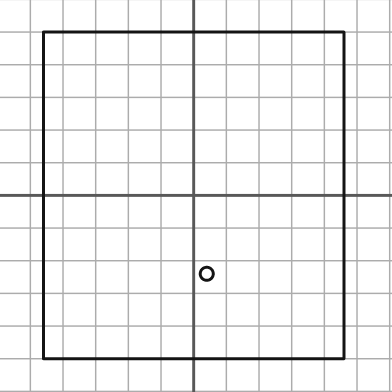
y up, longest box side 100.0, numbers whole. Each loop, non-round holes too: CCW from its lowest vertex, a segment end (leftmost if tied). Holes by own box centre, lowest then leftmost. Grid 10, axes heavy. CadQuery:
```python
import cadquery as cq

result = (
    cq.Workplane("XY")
    .moveTo(-46.0, -50.0)
    .lineTo(46.0, -50.0)
    .lineTo(46.0, 50.0)
    .lineTo(-46.0, 50.0)
    .close()
    .moveTo(4.0, -24.0)
    .circle(2.0)
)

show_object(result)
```